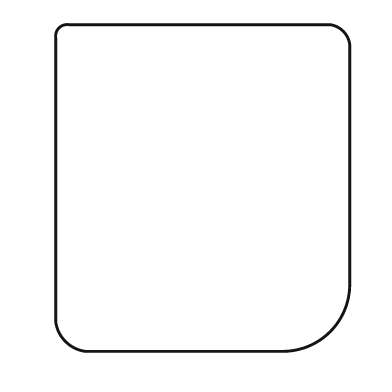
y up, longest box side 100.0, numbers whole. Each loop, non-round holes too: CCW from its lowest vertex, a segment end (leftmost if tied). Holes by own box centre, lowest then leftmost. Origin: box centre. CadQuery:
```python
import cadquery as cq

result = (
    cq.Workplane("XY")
    .moveTo(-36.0, -50.0)
    .lineTo(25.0, -50.0)
    .threePointArc((39.0, -44.0), (45.0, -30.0))
    .lineTo(45.0, 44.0)
    .threePointArc((43.0, 48.0), (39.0, 50.0))
    .lineTo(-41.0, 50.0)
    .threePointArc((-44.0, 49.0), (-45.0, 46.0))
    .lineTo(-45.0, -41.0)
    .threePointArc((-42.0, -47.0), (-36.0, -50.0))
    .close()
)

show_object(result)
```